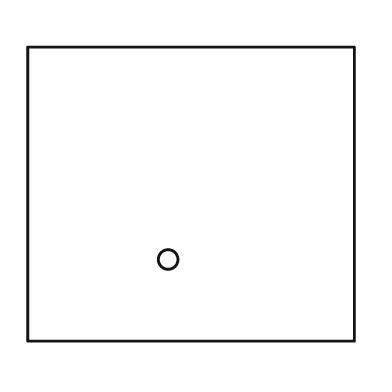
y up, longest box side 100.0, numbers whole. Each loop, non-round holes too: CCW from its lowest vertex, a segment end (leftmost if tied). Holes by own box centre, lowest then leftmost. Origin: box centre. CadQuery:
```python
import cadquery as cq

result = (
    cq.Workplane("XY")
    .moveTo(-50.0, -45.0)
    .lineTo(50.0, -45.0)
    .lineTo(50.0, 45.0)
    .lineTo(-50.0, 45.0)
    .close()
    .moveTo(-7.0, -20.0)
    .circle(3.0)
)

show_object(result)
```